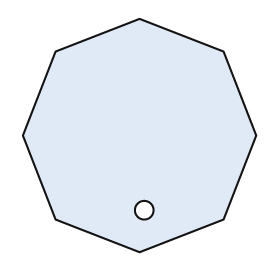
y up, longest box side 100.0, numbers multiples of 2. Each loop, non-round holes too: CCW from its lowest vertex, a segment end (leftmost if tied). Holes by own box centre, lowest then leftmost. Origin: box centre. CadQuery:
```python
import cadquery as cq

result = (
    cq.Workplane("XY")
    .moveTo(0.0, -50.0)
    .lineTo(36.0, -36.0)
    .lineTo(50.0, 0.0)
    .lineTo(36.0, 36.0)
    .lineTo(0.0, 50.0)
    .lineTo(-36.0, 36.0)
    .lineTo(-50.0, 0.0)
    .lineTo(-36.0, -36.0)
    .close()
    .moveTo(2.0, -32.0)
    .circle(4.0)
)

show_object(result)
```